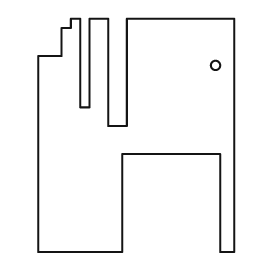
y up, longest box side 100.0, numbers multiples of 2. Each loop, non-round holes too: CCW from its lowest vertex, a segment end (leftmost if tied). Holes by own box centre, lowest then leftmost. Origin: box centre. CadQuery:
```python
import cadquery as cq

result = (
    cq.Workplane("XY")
    .moveTo(-42.0, -50.0)
    .lineTo(-6.0, -50.0)
    .lineTo(-6.0, -8.0)
    .lineTo(36.0, -8.0)
    .lineTo(36.0, -50.0)
    .lineTo(42.0, -50.0)
    .lineTo(42.0, 50.0)
    .lineTo(-4.0, 50.0)
    .lineTo(-4.0, 4.0)
    .lineTo(-12.0, 4.0)
    .lineTo(-12.0, 50.0)
    .lineTo(-20.0, 50.0)
    .lineTo(-20.0, 12.0)
    .lineTo(-24.0, 12.0)
    .lineTo(-24.0, 50.0)
    .lineTo(-28.0, 50.0)
    .lineTo(-28.0, 46.0)
    .lineTo(-32.0, 46.0)
    .lineTo(-32.0, 34.0)
    .lineTo(-42.0, 34.0)
    .close()
    .moveTo(34.0, 30.0)
    .circle(2.0)
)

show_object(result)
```